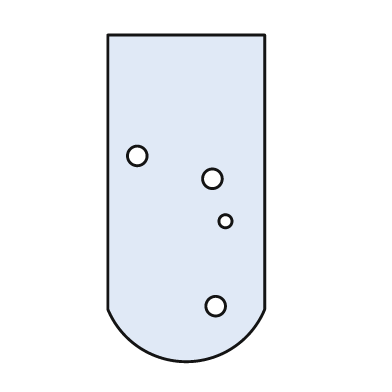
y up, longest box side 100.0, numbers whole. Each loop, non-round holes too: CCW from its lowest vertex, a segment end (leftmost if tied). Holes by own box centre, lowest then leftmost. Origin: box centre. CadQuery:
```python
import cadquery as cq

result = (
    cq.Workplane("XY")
    .moveTo(-24.0, -34.0)
    .threePointArc((0.0, -50.0), (24.0, -34.0))
    .lineTo(24.0, 50.0)
    .lineTo(-24.0, 50.0)
    .close()
    .moveTo(9.0, -33.0)
    .circle(3.0)
    .moveTo(12.0, -7.0)
    .circle(2.0)
    .moveTo(8.0, 6.0)
    .circle(3.0)
    .moveTo(-15.0, 13.0)
    .circle(3.0)
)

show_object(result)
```